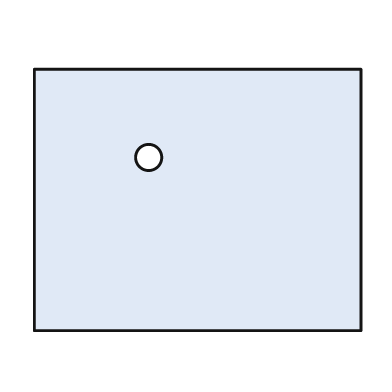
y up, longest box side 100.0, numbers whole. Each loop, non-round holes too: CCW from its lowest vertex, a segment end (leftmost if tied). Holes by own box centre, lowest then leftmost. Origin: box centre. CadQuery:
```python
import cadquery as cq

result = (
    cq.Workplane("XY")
    .moveTo(-50.0, -40.0)
    .lineTo(50.0, -40.0)
    .lineTo(50.0, 40.0)
    .lineTo(-50.0, 40.0)
    .close()
    .moveTo(-15.0, 13.0)
    .circle(4.0)
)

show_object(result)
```